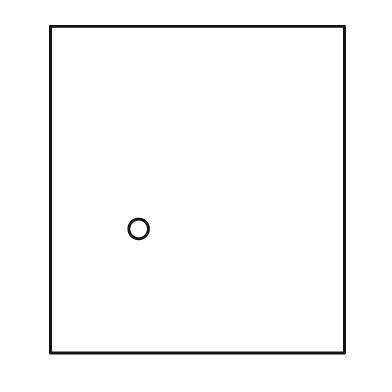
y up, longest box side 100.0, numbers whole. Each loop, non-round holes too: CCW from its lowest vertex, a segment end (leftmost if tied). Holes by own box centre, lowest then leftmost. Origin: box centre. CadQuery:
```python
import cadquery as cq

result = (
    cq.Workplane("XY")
    .moveTo(-45.0, -50.0)
    .lineTo(45.0, -50.0)
    .lineTo(45.0, 50.0)
    .lineTo(-45.0, 50.0)
    .close()
    .moveTo(-18.0, -12.0)
    .circle(3.0)
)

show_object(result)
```